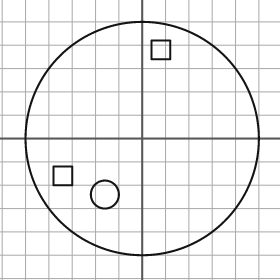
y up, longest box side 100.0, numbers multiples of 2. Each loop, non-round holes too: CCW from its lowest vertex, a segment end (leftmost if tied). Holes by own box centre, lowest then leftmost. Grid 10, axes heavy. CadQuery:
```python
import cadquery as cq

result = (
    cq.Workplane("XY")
    .moveTo(0.0, 0.0)
    .circle(50.0)
    .moveTo(-16.0, -24.0)
    .circle(6.0)
    .moveTo(-38.0, -20.0)
    .lineTo(-30.0, -20.0)
    .lineTo(-30.0, -12.0)
    .lineTo(-38.0, -12.0)
    .close()
    .moveTo(4.0, 34.0)
    .lineTo(12.0, 34.0)
    .lineTo(12.0, 42.0)
    .lineTo(4.0, 42.0)
    .close()
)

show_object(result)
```